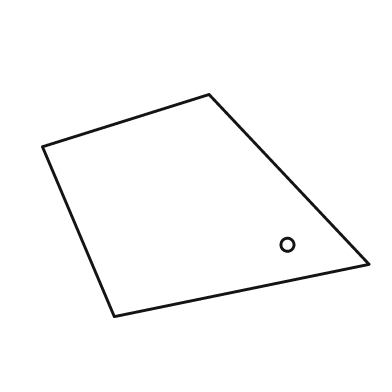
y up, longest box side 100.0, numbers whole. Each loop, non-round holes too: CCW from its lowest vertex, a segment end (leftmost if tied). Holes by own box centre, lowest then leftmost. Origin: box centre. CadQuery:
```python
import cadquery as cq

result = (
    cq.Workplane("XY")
    .moveTo(-28.0, -34.0)
    .lineTo(50.0, -18.0)
    .lineTo(1.0, 34.0)
    .lineTo(-50.0, 18.0)
    .close()
    .moveTo(25.0, -12.0)
    .circle(2.0)
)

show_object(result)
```